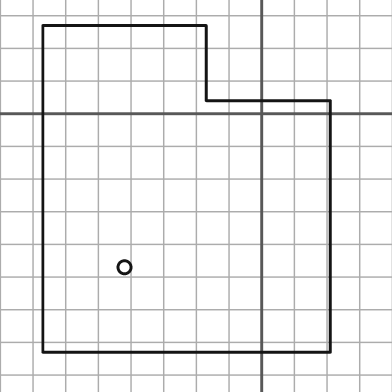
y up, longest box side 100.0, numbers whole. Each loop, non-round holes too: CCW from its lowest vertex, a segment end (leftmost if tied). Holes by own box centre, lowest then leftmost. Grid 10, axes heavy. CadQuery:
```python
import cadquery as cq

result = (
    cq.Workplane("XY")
    .moveTo(-67.0, -73.0)
    .lineTo(21.0, -73.0)
    .lineTo(21.0, 4.0)
    .lineTo(-17.0, 4.0)
    .lineTo(-17.0, 27.0)
    .lineTo(-67.0, 27.0)
    .close()
    .moveTo(-42.0, -47.0)
    .circle(2.0)
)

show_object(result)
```